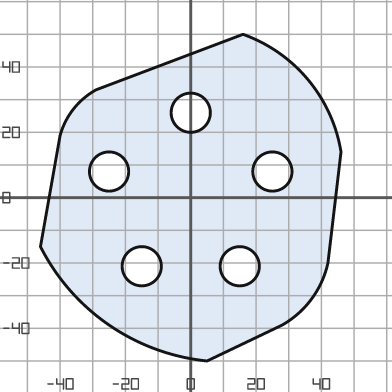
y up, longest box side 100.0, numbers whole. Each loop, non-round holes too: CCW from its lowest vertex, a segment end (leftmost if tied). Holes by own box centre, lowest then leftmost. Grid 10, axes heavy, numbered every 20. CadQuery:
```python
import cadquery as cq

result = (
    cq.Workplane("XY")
    .moveTo(5.0, -50.0)
    .lineTo(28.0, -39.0)
    .threePointArc((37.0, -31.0), (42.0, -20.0))
    .lineTo(46.0, 14.0)
    .threePointArc((36.0, 36.0), (16.0, 50.0))
    .lineTo(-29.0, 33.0)
    .threePointArc((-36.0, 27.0), (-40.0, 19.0))
    .lineTo(-46.0, -15.0)
    .threePointArc((-25.0, -39.0), (5.0, -50.0))
    .close()
    .moveTo(-15.0, -21.0)
    .circle(6.0)
    .moveTo(15.0, -21.0)
    .circle(6.0)
    .moveTo(-25.0, 8.0)
    .circle(6.0)
    .moveTo(25.0, 8.0)
    .circle(6.0)
    .moveTo(0.0, 26.0)
    .circle(6.0)
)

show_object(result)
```